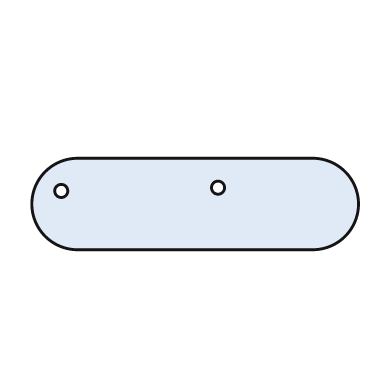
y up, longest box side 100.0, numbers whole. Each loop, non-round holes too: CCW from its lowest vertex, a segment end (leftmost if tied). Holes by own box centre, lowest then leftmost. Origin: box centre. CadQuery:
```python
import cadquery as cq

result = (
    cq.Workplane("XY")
    .moveTo(-36.0, -14.0)
    .lineTo(36.0, -14.0)
    .threePointArc((50.0, 0.0), (36.0, 14.0))
    .lineTo(-36.0, 14.0)
    .threePointArc((-50.0, 0.0), (-36.0, -14.0))
    .close()
    .moveTo(-41.0, 4.0)
    .circle(2.0)
    .moveTo(7.0, 5.0)
    .circle(2.0)
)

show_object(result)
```